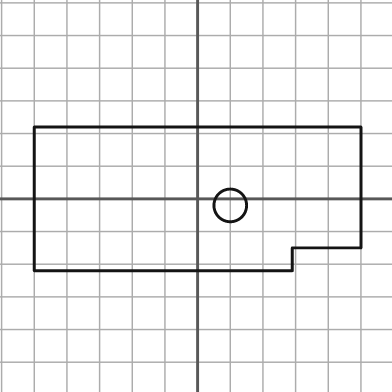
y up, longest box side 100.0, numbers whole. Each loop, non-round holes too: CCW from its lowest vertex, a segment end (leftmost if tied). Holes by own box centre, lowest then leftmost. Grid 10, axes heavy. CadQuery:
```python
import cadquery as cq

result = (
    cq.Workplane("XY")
    .moveTo(-50.0, -22.0)
    .lineTo(29.0, -22.0)
    .lineTo(29.0, -15.0)
    .lineTo(50.0, -15.0)
    .lineTo(50.0, 22.0)
    .lineTo(-50.0, 22.0)
    .close()
    .moveTo(10.0, -2.0)
    .circle(5.0)
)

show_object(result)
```